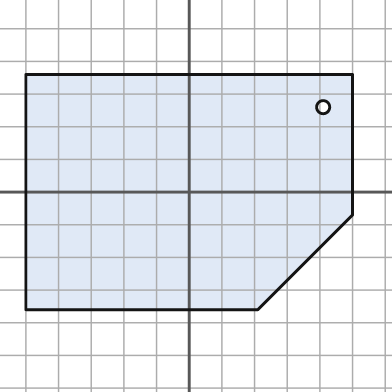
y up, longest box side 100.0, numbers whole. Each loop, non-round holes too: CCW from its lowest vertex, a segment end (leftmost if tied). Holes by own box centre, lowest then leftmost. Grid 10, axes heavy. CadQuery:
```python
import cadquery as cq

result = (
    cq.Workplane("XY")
    .moveTo(-50.0, -36.0)
    .lineTo(21.0, -36.0)
    .lineTo(50.0, -7.0)
    .lineTo(50.0, 36.0)
    .lineTo(-50.0, 36.0)
    .close()
    .moveTo(41.0, 26.0)
    .circle(2.0)
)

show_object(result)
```